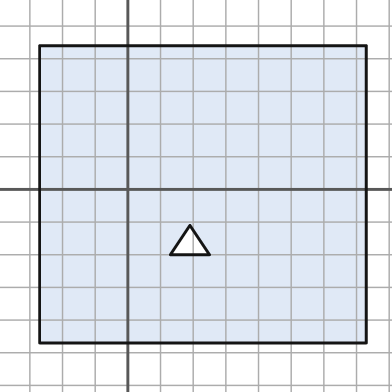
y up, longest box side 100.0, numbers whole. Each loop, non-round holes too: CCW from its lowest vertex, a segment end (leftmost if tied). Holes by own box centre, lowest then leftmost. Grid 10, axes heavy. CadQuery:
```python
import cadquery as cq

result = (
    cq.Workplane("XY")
    .moveTo(-27.0, -47.0)
    .lineTo(73.0, -47.0)
    .lineTo(73.0, 44.0)
    .lineTo(-27.0, 44.0)
    .close()
    .moveTo(13.0, -20.0)
    .lineTo(25.0, -20.0)
    .lineTo(19.0, -11.0)
    .close()
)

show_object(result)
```